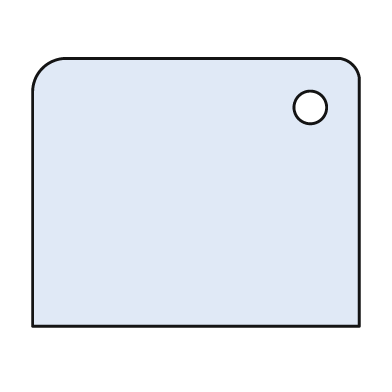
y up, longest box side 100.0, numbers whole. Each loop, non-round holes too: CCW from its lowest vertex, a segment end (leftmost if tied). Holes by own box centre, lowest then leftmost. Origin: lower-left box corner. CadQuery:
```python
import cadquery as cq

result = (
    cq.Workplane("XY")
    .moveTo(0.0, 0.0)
    .lineTo(100.0, 0.0)
    .lineTo(100.0, 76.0)
    .threePointArc((98.0, 80.0), (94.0, 82.0))
    .lineTo(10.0, 82.0)
    .threePointArc((3.0, 79.0), (0.0, 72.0))
    .close()
    .moveTo(85.0, 67.0)
    .circle(5.0)
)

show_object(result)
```